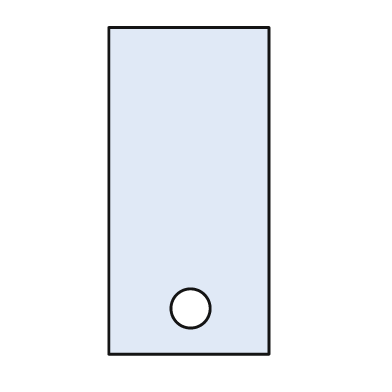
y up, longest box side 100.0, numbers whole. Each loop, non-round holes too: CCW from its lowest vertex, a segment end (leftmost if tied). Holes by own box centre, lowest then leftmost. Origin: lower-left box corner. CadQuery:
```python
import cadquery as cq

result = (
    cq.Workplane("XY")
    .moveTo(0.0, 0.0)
    .lineTo(49.0, 0.0)
    .lineTo(49.0, 100.0)
    .lineTo(0.0, 100.0)
    .close()
    .moveTo(25.0, 14.0)
    .circle(6.0)
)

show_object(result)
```